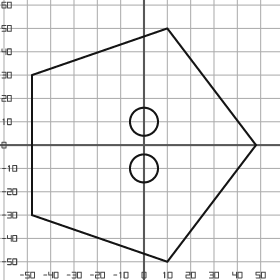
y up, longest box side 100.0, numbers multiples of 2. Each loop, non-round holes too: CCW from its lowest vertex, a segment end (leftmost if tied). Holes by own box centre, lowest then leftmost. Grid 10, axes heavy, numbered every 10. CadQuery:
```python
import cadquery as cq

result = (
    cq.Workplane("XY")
    .moveTo(10.0, -50.0)
    .lineTo(48.0, 0.0)
    .lineTo(10.0, 50.0)
    .lineTo(-48.0, 30.0)
    .lineTo(-48.0, -30.0)
    .close()
    .moveTo(0.0, -10.0)
    .circle(6.0)
    .moveTo(0.0, 10.0)
    .circle(6.0)
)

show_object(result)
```